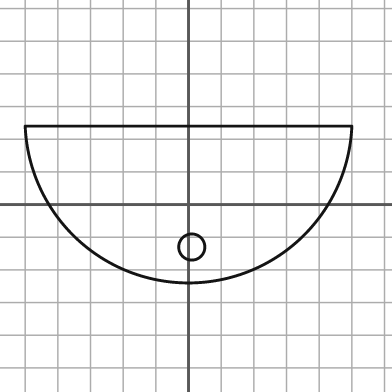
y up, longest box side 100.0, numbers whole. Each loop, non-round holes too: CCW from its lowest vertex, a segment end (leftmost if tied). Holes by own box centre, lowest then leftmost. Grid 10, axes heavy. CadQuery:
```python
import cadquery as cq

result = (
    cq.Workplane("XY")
    .moveTo(-50.0, 24.0)
    .threePointArc((0.0, -24.0), (50.0, 24.0))
    .close()
    .moveTo(1.0, -13.0)
    .circle(4.0)
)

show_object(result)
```